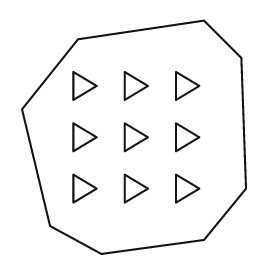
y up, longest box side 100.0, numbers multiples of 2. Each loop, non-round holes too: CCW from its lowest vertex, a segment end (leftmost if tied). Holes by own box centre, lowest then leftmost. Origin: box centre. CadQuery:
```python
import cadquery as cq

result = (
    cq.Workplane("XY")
    .moveTo(-14.0, -50.0)
    .lineTo(30.0, -44.0)
    .lineTo(48.0, -22.0)
    .lineTo(46.0, 34.0)
    .lineTo(30.0, 50.0)
    .lineTo(-24.0, 42.0)
    .lineTo(-48.0, 12.0)
    .lineTo(-36.0, -38.0)
    .close()
    .moveTo(-26.0, -28.0)
    .lineTo(-16.0, -22.0)
    .lineTo(-26.0, -16.0)
    .close()
    .moveTo(-4.0, -28.0)
    .lineTo(6.0, -22.0)
    .lineTo(-4.0, -16.0)
    .close()
    .moveTo(18.0, -28.0)
    .lineTo(28.0, -22.0)
    .lineTo(18.0, -16.0)
    .close()
    .moveTo(-26.0, -6.0)
    .lineTo(-16.0, 0.0)
    .lineTo(-26.0, 6.0)
    .close()
    .moveTo(-4.0, -6.0)
    .lineTo(6.0, 0.0)
    .lineTo(-4.0, 6.0)
    .close()
    .moveTo(18.0, -6.0)
    .lineTo(28.0, 0.0)
    .lineTo(18.0, 6.0)
    .close()
    .moveTo(-26.0, 16.0)
    .lineTo(-16.0, 22.0)
    .lineTo(-26.0, 28.0)
    .close()
    .moveTo(-4.0, 16.0)
    .lineTo(6.0, 22.0)
    .lineTo(-4.0, 28.0)
    .close()
    .moveTo(18.0, 16.0)
    .lineTo(28.0, 22.0)
    .lineTo(18.0, 28.0)
    .close()
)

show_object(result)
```